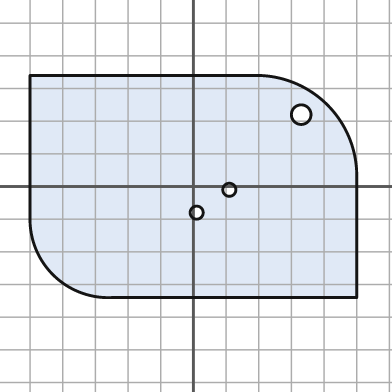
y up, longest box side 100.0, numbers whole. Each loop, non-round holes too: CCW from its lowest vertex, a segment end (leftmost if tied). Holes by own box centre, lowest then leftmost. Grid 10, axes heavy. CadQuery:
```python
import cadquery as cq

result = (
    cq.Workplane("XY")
    .moveTo(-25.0, -34.0)
    .lineTo(50.0, -34.0)
    .lineTo(50.0, 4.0)
    .threePointArc((41.0, 25.0), (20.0, 34.0))
    .lineTo(-50.0, 34.0)
    .lineTo(-50.0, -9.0)
    .threePointArc((-43.0, -27.0), (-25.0, -34.0))
    .close()
    .moveTo(1.0, -8.0)
    .circle(2.0)
    .moveTo(11.0, -1.0)
    .circle(2.0)
    .moveTo(33.0, 22.0)
    .circle(3.0)
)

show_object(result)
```